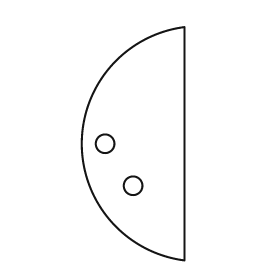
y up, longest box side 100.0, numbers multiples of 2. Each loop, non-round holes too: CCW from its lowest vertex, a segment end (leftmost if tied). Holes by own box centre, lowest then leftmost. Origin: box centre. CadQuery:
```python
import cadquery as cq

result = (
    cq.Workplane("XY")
    .moveTo(22.0, -50.0)
    .lineTo(22.0, 50.0)
    .threePointArc((-22.0, 0.0), (22.0, -50.0))
    .close()
    .moveTo(0.0, -18.0)
    .circle(4.0)
    .moveTo(-12.0, 0.0)
    .circle(4.0)
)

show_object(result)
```